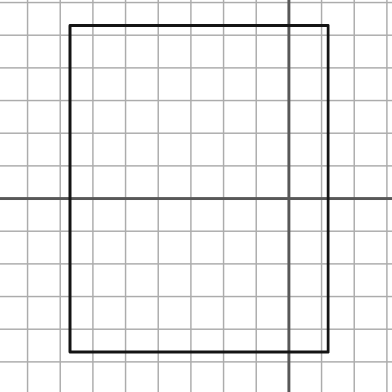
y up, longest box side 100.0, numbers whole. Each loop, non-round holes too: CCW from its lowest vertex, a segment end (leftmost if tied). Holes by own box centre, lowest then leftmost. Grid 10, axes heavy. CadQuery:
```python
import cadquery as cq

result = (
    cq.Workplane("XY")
    .moveTo(-67.0, -47.0)
    .lineTo(12.0, -47.0)
    .lineTo(12.0, 53.0)
    .lineTo(-67.0, 53.0)
    .close()
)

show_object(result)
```